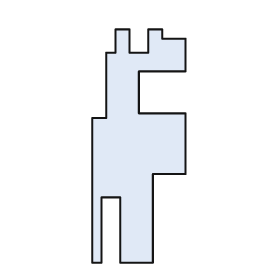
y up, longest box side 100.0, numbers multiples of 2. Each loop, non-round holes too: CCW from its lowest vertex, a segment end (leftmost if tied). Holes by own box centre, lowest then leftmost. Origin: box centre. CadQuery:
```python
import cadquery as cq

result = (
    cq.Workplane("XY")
    .moveTo(-20.0, -50.0)
    .lineTo(-16.0, -50.0)
    .lineTo(-16.0, -22.0)
    .lineTo(-8.0, -22.0)
    .lineTo(-8.0, -50.0)
    .lineTo(6.0, -50.0)
    .lineTo(6.0, -12.0)
    .lineTo(20.0, -12.0)
    .lineTo(20.0, 14.0)
    .lineTo(0.0, 14.0)
    .lineTo(0.0, 32.0)
    .lineTo(20.0, 32.0)
    .lineTo(20.0, 46.0)
    .lineTo(10.0, 46.0)
    .lineTo(10.0, 50.0)
    .lineTo(4.0, 50.0)
    .lineTo(4.0, 40.0)
    .lineTo(-4.0, 40.0)
    .lineTo(-4.0, 50.0)
    .lineTo(-10.0, 50.0)
    .lineTo(-10.0, 40.0)
    .lineTo(-14.0, 40.0)
    .lineTo(-14.0, 12.0)
    .lineTo(-20.0, 12.0)
    .close()
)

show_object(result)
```